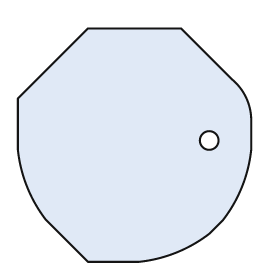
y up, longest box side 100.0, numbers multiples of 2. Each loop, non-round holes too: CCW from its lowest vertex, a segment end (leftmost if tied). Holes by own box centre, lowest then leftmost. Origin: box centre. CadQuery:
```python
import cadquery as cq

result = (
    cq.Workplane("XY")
    .moveTo(-20.0, -50.0)
    .lineTo(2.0, -50.0)
    .threePointArc((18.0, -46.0), (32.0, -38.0))
    .lineTo(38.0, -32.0)
    .threePointArc((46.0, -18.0), (50.0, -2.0))
    .lineTo(50.0, 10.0)
    .threePointArc((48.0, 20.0), (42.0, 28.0))
    .lineTo(20.0, 50.0)
    .lineTo(-20.0, 50.0)
    .lineTo(-50.0, 20.0)
    .lineTo(-50.0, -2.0)
    .threePointArc((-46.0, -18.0), (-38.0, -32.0))
    .close()
    .moveTo(32.0, 2.0)
    .circle(4.0)
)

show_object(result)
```